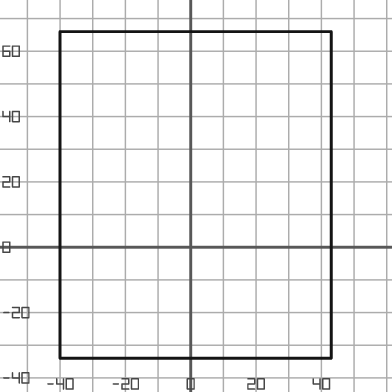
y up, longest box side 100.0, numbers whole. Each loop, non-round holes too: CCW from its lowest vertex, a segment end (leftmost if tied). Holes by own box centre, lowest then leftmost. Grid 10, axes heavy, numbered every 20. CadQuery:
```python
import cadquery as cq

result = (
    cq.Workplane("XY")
    .moveTo(-40.0, -34.0)
    .lineTo(43.0, -34.0)
    .lineTo(43.0, 66.0)
    .lineTo(-40.0, 66.0)
    .close()
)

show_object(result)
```